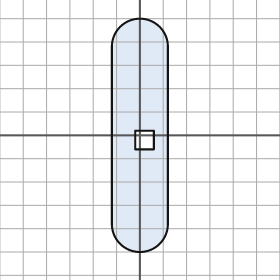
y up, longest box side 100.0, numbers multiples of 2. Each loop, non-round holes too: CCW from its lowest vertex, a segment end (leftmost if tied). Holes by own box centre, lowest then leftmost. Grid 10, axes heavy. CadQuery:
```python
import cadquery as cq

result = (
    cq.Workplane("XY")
    .moveTo(-12.0, -38.0)
    .threePointArc((0.0, -50.0), (12.0, -38.0))
    .lineTo(12.0, 38.0)
    .threePointArc((0.0, 50.0), (-12.0, 38.0))
    .close()
    .moveTo(-2.0, -6.0)
    .lineTo(6.0, -6.0)
    .lineTo(6.0, 2.0)
    .lineTo(-2.0, 2.0)
    .close()
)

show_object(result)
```